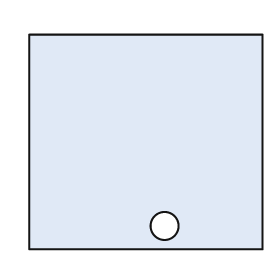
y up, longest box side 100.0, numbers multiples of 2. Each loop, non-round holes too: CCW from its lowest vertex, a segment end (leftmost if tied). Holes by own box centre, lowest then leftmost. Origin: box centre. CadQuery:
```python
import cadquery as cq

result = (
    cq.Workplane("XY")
    .moveTo(-50.0, -46.0)
    .lineTo(50.0, -46.0)
    .lineTo(50.0, 46.0)
    .lineTo(-50.0, 46.0)
    .close()
    .moveTo(8.0, -36.0)
    .circle(6.0)
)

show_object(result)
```